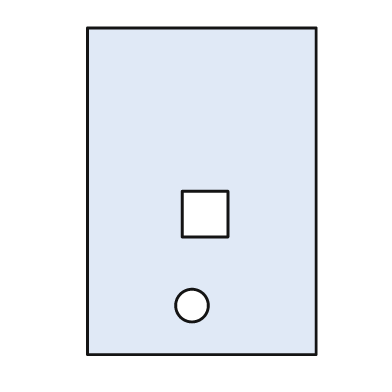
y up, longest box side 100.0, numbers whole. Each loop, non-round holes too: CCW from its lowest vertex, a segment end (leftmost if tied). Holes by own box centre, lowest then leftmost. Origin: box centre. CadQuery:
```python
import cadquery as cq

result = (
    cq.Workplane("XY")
    .moveTo(-35.0, -50.0)
    .lineTo(35.0, -50.0)
    .lineTo(35.0, 50.0)
    .lineTo(-35.0, 50.0)
    .close()
    .moveTo(-3.0, -35.0)
    .circle(5.0)
    .moveTo(-6.0, -14.0)
    .lineTo(8.0, -14.0)
    .lineTo(8.0, 0.0)
    .lineTo(-6.0, 0.0)
    .close()
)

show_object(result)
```